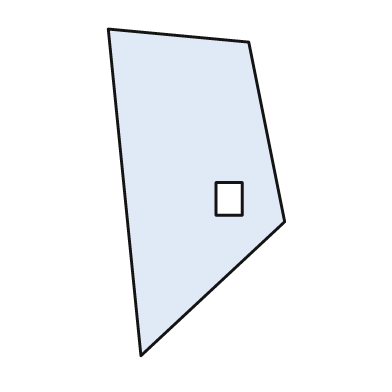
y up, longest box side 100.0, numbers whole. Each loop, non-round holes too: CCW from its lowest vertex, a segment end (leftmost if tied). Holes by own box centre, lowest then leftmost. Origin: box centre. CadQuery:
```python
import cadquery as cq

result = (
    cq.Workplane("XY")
    .moveTo(-17.0, -50.0)
    .lineTo(27.0, -9.0)
    .lineTo(16.0, 46.0)
    .lineTo(-27.0, 50.0)
    .close()
    .moveTo(6.0, -7.0)
    .lineTo(14.0, -7.0)
    .lineTo(14.0, 3.0)
    .lineTo(6.0, 3.0)
    .close()
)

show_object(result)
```